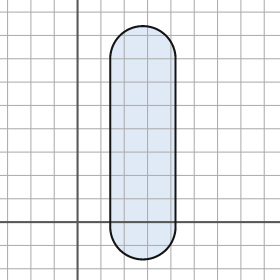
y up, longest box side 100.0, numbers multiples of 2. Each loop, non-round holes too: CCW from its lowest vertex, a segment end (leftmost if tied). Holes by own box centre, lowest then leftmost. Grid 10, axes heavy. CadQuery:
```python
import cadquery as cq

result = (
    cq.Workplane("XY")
    .moveTo(14.0, -2.0)
    .threePointArc((28.0, -16.0), (42.0, -2.0))
    .lineTo(42.0, 70.0)
    .threePointArc((28.0, 84.0), (14.0, 70.0))
    .close()
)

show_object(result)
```